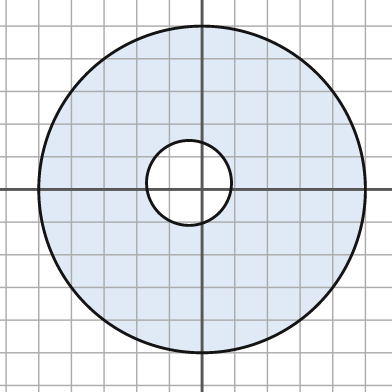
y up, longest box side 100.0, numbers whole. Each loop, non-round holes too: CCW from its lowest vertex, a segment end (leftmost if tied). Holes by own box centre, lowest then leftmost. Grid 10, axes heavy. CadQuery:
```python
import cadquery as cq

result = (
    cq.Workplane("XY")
    .moveTo(0.0, 0.0)
    .circle(50.0)
    .moveTo(-4.0, 2.0)
    .circle(13.0)
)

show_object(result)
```